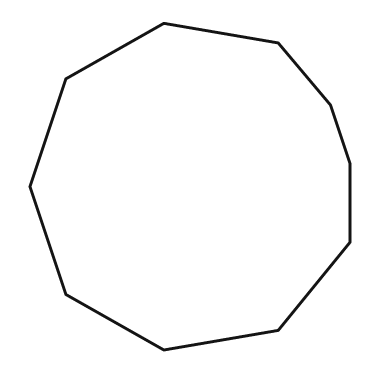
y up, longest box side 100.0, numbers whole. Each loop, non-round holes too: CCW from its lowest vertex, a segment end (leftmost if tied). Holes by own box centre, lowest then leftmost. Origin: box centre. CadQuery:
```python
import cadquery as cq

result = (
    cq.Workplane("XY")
    .moveTo(-8.0, -50.0)
    .lineTo(27.0, -44.0)
    .lineTo(49.0, -17.0)
    .lineTo(49.0, 7.0)
    .lineTo(43.0, 25.0)
    .lineTo(27.0, 44.0)
    .lineTo(-8.0, 50.0)
    .lineTo(-38.0, 33.0)
    .lineTo(-49.0, 0.0)
    .lineTo(-38.0, -33.0)
    .close()
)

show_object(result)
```